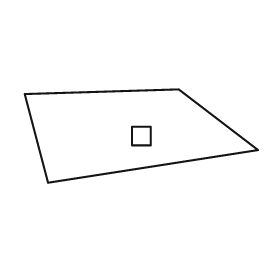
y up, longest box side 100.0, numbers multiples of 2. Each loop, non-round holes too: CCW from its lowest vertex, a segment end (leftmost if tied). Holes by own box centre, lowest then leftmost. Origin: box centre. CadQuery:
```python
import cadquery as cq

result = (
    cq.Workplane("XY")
    .moveTo(-40.0, -20.0)
    .lineTo(50.0, -6.0)
    .lineTo(16.0, 20.0)
    .lineTo(-50.0, 18.0)
    .close()
    .moveTo(-4.0, -4.0)
    .lineTo(4.0, -4.0)
    .lineTo(4.0, 4.0)
    .lineTo(-4.0, 4.0)
    .close()
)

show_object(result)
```